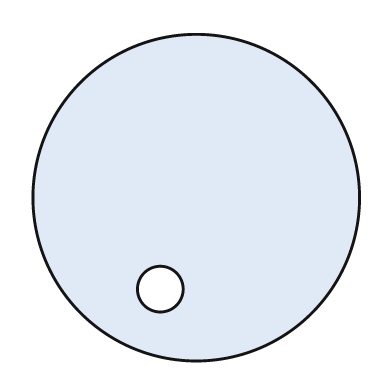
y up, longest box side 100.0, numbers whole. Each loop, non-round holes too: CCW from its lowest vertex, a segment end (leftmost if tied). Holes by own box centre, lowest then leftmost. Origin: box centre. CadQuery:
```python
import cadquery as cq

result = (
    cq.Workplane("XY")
    .moveTo(0.0, 0.0)
    .circle(50.0)
    .moveTo(-11.0, -28.0)
    .circle(7.0)
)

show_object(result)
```